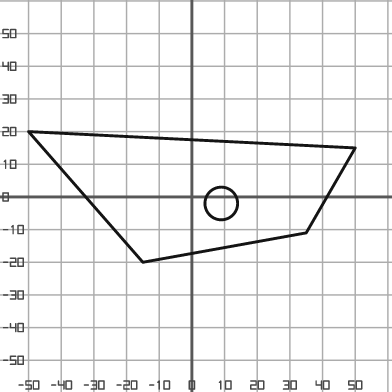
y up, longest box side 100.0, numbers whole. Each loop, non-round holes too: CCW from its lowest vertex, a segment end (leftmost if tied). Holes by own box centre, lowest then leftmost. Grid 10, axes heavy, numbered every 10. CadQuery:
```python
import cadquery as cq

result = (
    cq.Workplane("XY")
    .moveTo(-15.0, -20.0)
    .lineTo(35.0, -11.0)
    .lineTo(50.0, 15.0)
    .lineTo(-50.0, 20.0)
    .close()
    .moveTo(9.0, -2.0)
    .circle(5.0)
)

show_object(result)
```